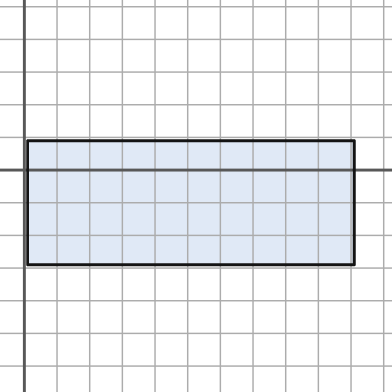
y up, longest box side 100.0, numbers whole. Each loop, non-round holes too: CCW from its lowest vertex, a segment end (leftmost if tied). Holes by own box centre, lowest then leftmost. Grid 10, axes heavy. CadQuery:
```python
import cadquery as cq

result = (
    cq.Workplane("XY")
    .moveTo(1.0, -29.0)
    .lineTo(101.0, -29.0)
    .lineTo(101.0, 9.0)
    .lineTo(1.0, 9.0)
    .close()
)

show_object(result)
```